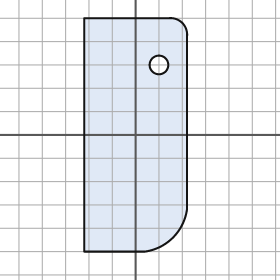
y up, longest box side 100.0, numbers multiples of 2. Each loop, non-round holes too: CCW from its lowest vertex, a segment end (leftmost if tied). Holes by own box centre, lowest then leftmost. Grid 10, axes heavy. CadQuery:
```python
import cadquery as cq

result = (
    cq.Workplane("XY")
    .moveTo(-22.0, -50.0)
    .lineTo(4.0, -50.0)
    .threePointArc((16.0, -44.0), (22.0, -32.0))
    .lineTo(22.0, 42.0)
    .threePointArc((20.0, 48.0), (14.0, 50.0))
    .lineTo(-22.0, 50.0)
    .close()
    .moveTo(10.0, 30.0)
    .circle(4.0)
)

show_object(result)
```